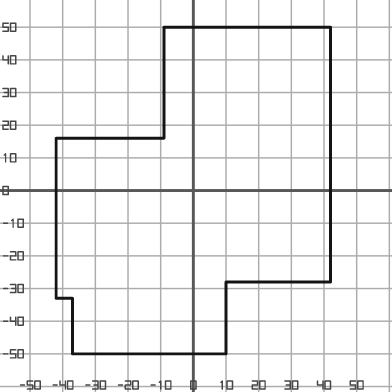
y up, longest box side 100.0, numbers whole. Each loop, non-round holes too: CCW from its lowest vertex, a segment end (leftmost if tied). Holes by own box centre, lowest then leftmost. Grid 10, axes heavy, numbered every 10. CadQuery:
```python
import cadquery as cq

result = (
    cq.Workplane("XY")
    .moveTo(-37.0, -50.0)
    .lineTo(10.0, -50.0)
    .lineTo(10.0, -28.0)
    .lineTo(42.0, -28.0)
    .lineTo(42.0, 50.0)
    .lineTo(-9.0, 50.0)
    .lineTo(-9.0, 16.0)
    .lineTo(-42.0, 16.0)
    .lineTo(-42.0, -33.0)
    .lineTo(-37.0, -33.0)
    .close()
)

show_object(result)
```